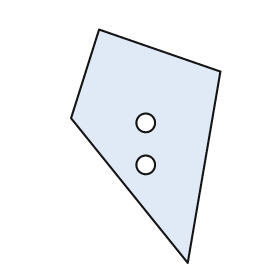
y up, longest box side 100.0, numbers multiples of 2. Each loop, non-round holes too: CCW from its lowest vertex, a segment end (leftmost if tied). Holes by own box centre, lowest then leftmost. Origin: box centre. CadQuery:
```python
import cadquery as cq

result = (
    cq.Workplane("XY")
    .moveTo(18.0, -50.0)
    .lineTo(32.0, 32.0)
    .lineTo(-20.0, 50.0)
    .lineTo(-32.0, 12.0)
    .close()
    .moveTo(0.0, -8.0)
    .circle(4.0)
    .moveTo(0.0, 10.0)
    .circle(4.0)
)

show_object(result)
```